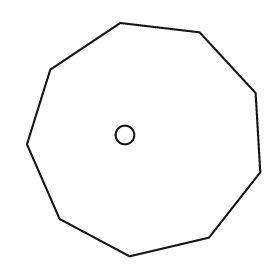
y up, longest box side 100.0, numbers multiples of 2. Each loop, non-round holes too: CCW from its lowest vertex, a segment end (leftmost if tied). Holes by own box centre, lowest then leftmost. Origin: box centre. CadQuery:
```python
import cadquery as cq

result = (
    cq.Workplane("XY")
    .moveTo(-6.0, -50.0)
    .lineTo(28.0, -42.0)
    .lineTo(50.0, -14.0)
    .lineTo(48.0, 20.0)
    .lineTo(24.0, 46.0)
    .lineTo(-10.0, 50.0)
    .lineTo(-40.0, 30.0)
    .lineTo(-50.0, -2.0)
    .lineTo(-36.0, -34.0)
    .close()
    .moveTo(-8.0, 2.0)
    .circle(4.0)
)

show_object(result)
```